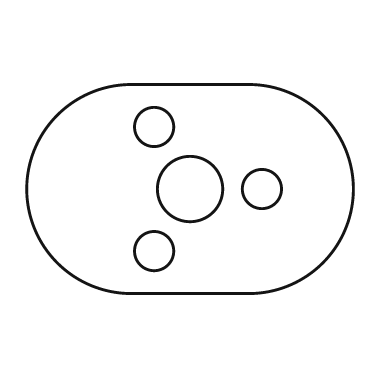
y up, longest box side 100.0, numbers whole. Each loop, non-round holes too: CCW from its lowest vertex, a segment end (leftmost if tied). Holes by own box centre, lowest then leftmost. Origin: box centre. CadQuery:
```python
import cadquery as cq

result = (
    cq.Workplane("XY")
    .moveTo(-18.0, -32.0)
    .lineTo(18.0, -32.0)
    .threePointArc((50.0, 0.0), (18.0, 32.0))
    .lineTo(-18.0, 32.0)
    .threePointArc((-50.0, 0.0), (-18.0, -32.0))
    .close()
    .moveTo(-11.0, -19.0)
    .circle(6.0)
    .moveTo(0.0, 0.0)
    .circle(10.0)
    .moveTo(22.0, 0.0)
    .circle(6.0)
    .moveTo(-11.0, 19.0)
    .circle(6.0)
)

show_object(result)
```